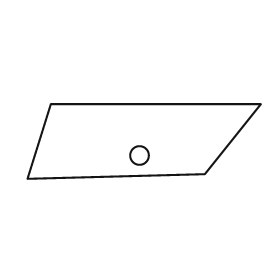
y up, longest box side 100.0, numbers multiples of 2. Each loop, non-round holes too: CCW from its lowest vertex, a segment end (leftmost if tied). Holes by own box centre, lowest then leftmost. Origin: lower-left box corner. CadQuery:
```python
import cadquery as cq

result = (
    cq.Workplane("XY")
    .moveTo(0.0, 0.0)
    .lineTo(76.0, 2.0)
    .lineTo(100.0, 32.0)
    .lineTo(10.0, 32.0)
    .close()
    .moveTo(48.0, 10.0)
    .circle(4.0)
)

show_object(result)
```